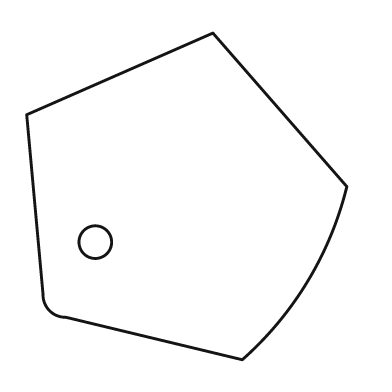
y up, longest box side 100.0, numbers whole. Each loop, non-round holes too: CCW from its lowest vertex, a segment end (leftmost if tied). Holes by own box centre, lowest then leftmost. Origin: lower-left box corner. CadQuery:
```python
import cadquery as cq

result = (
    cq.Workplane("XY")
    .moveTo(66.0, 0.0)
    .threePointArc((86.0, 24.0), (98.0, 53.0))
    .lineTo(57.0, 100.0)
    .lineTo(0.0, 75.0)
    .lineTo(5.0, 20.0)
    .threePointArc((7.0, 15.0), (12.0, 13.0))
    .close()
    .moveTo(21.0, 36.0)
    .circle(5.0)
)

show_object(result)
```